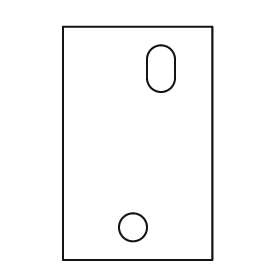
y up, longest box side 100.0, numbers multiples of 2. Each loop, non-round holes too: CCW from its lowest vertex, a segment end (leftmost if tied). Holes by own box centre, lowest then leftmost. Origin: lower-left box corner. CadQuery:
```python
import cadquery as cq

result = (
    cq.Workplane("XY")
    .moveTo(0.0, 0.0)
    .lineTo(64.0, 0.0)
    .lineTo(64.0, 100.0)
    .lineTo(0.0, 100.0)
    .close()
    .moveTo(30.0, 14.0)
    .circle(6.0)
    .moveTo(36.0, 78.0)
    .threePointArc((42.0, 72.0), (48.0, 78.0))
    .lineTo(48.0, 86.0)
    .threePointArc((42.0, 92.0), (36.0, 86.0))
    .close()
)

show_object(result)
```